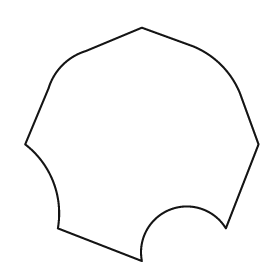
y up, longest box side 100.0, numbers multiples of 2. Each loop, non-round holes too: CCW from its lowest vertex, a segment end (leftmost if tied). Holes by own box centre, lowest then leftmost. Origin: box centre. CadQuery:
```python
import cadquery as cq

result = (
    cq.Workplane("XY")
    .moveTo(0.0, -50.0)
    .threePointArc((12.0, -28.0), (36.0, -36.0))
    .lineTo(50.0, 0.0)
    .lineTo(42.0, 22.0)
    .threePointArc((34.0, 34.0), (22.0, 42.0))
    .lineTo(0.0, 50.0)
    .lineTo(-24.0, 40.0)
    .threePointArc((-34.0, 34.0), (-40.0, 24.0))
    .lineTo(-50.0, 0.0)
    .threePointArc((-38.0, -16.0), (-36.0, -36.0))
    .close()
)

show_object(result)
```